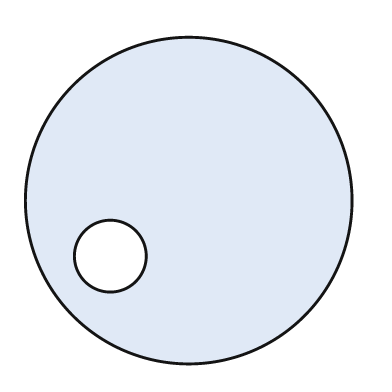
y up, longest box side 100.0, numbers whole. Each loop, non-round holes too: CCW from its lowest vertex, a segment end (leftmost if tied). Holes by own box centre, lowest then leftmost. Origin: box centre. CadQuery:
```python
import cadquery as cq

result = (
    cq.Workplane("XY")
    .moveTo(0.0, 0.0)
    .circle(50.0)
    .moveTo(-24.0, -17.0)
    .circle(11.0)
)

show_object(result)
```